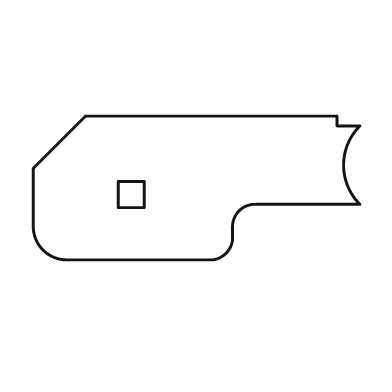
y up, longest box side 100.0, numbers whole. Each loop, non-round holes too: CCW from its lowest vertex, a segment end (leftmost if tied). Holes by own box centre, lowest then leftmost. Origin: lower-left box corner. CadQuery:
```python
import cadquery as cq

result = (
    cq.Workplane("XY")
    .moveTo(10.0, 0.0)
    .lineTo(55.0, 0.0)
    .threePointArc((59.0, 2.0), (61.0, 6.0))
    .lineTo(61.0, 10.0)
    .threePointArc((63.0, 15.0), (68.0, 17.0))
    .lineTo(100.0, 17.0)
    .threePointArc((95.0, 29.0), (100.0, 41.0))
    .lineTo(93.0, 41.0)
    .lineTo(93.0, 44.0)
    .lineTo(16.0, 44.0)
    .lineTo(0.0, 28.0)
    .lineTo(0.0, 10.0)
    .threePointArc((3.0, 3.0), (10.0, 0.0))
    .close()
    .moveTo(26.0, 16.0)
    .lineTo(34.0, 16.0)
    .lineTo(34.0, 24.0)
    .lineTo(26.0, 24.0)
    .close()
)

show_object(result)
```